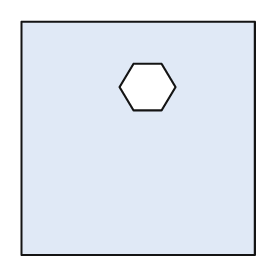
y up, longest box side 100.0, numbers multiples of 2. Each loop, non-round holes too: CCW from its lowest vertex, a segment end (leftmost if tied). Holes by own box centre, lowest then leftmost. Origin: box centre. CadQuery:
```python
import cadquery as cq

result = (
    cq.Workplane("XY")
    .moveTo(-50.0, -50.0)
    .lineTo(50.0, -50.0)
    .lineTo(50.0, 50.0)
    .lineTo(-50.0, 50.0)
    .close()
    .moveTo(-2.0, 12.0)
    .lineTo(10.0, 12.0)
    .lineTo(16.0, 22.0)
    .lineTo(10.0, 32.0)
    .lineTo(-2.0, 32.0)
    .lineTo(-8.0, 22.0)
    .close()
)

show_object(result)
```